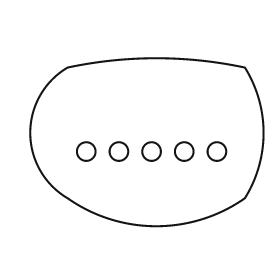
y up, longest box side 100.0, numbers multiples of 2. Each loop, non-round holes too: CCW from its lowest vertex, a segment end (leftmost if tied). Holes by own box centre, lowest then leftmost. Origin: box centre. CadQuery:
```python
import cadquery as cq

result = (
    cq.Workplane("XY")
    .moveTo(-34.0, -24.0)
    .threePointArc((4.0, -36.0), (42.0, -24.0))
    .threePointArc((50.0, 4.0), (42.0, 32.0))
    .threePointArc((4.0, 36.0), (-34.0, 32.0))
    .threePointArc((-50.0, 4.0), (-34.0, -24.0))
    .close()
    .moveTo(-26.0, -4.0)
    .circle(4.0)
    .moveTo(-12.0, -4.0)
    .circle(4.0)
    .moveTo(2.0, -4.0)
    .circle(4.0)
    .moveTo(16.0, -4.0)
    .circle(4.0)
    .moveTo(30.0, -4.0)
    .circle(4.0)
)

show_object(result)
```